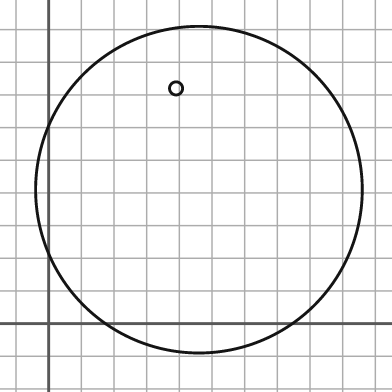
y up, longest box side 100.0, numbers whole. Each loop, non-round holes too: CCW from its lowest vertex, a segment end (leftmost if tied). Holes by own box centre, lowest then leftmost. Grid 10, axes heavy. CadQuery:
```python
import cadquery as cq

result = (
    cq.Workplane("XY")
    .moveTo(46.0, 41.0)
    .circle(50.0)
    .moveTo(39.0, 72.0)
    .circle(2.0)
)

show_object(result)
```